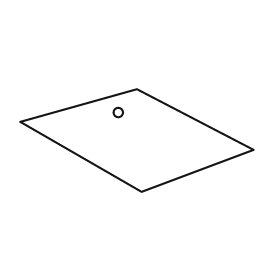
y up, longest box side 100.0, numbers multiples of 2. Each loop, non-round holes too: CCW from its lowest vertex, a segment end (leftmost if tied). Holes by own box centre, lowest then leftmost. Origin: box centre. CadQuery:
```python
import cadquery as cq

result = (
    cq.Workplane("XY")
    .moveTo(2.0, -22.0)
    .lineTo(50.0, -4.0)
    .lineTo(0.0, 22.0)
    .lineTo(-50.0, 8.0)
    .close()
    .moveTo(-8.0, 12.0)
    .circle(2.0)
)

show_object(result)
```